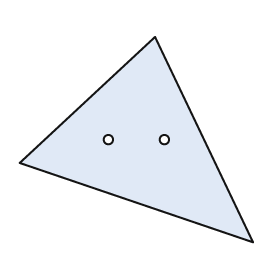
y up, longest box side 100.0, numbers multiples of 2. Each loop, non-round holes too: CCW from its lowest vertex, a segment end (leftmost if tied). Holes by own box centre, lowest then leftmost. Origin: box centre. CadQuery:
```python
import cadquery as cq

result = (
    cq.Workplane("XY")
    .moveTo(50.0, -44.0)
    .lineTo(8.0, 44.0)
    .lineTo(-50.0, -10.0)
    .close()
    .moveTo(-12.0, 0.0)
    .circle(2.0)
    .moveTo(12.0, 0.0)
    .circle(2.0)
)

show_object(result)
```